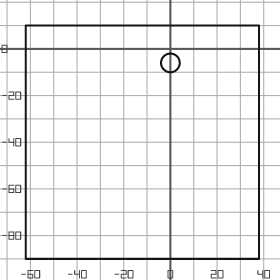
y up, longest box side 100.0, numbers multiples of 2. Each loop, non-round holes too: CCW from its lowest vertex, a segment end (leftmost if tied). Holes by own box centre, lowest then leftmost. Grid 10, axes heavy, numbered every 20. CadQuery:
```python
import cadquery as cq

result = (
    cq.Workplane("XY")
    .moveTo(-62.0, -90.0)
    .lineTo(38.0, -90.0)
    .lineTo(38.0, 10.0)
    .lineTo(-62.0, 10.0)
    .close()
    .moveTo(0.0, -6.0)
    .circle(4.0)
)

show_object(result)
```